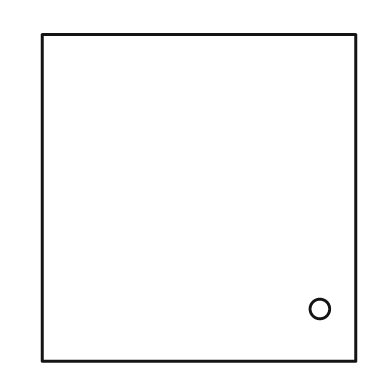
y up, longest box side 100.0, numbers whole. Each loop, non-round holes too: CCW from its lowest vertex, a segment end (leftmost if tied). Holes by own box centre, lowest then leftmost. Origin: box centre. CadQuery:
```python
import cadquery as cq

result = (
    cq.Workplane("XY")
    .moveTo(-48.0, -50.0)
    .lineTo(48.0, -50.0)
    .lineTo(48.0, 50.0)
    .lineTo(-48.0, 50.0)
    .close()
    .moveTo(37.0, -34.0)
    .circle(3.0)
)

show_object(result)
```